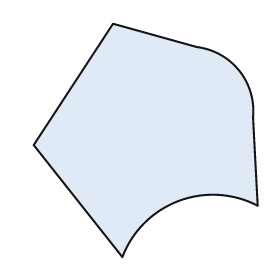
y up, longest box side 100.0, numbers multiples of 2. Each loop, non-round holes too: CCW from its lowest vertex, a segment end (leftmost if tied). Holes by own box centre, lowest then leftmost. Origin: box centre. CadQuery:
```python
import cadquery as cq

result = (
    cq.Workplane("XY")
    .moveTo(-10.0, -50.0)
    .threePointArc((14.0, -26.0), (48.0, -28.0))
    .lineTo(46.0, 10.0)
    .threePointArc((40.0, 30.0), (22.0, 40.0))
    .lineTo(-14.0, 50.0)
    .lineTo(-48.0, -2.0)
    .close()
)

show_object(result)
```